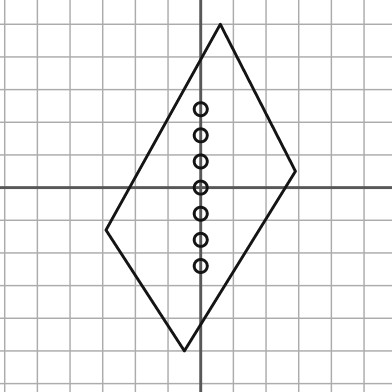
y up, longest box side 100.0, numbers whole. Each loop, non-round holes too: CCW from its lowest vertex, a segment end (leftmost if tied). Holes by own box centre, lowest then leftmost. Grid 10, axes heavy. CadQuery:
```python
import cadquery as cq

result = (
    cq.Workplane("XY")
    .moveTo(-5.0, -50.0)
    .lineTo(29.0, 5.0)
    .lineTo(6.0, 50.0)
    .lineTo(-29.0, -13.0)
    .close()
    .moveTo(0.0, -24.0)
    .circle(2.0)
    .moveTo(0.0, -16.0)
    .circle(2.0)
    .moveTo(0.0, -8.0)
    .circle(2.0)
    .moveTo(0.0, 0.0)
    .circle(2.0)
    .moveTo(0.0, 8.0)
    .circle(2.0)
    .moveTo(0.0, 16.0)
    .circle(2.0)
    .moveTo(0.0, 24.0)
    .circle(2.0)
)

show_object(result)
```